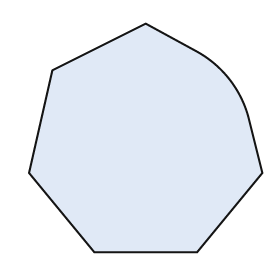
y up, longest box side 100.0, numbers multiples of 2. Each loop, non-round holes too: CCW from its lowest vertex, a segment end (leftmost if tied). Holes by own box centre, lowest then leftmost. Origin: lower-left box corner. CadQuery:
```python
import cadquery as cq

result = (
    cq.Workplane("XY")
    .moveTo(28.0, 0.0)
    .lineTo(72.0, 0.0)
    .lineTo(100.0, 34.0)
    .lineTo(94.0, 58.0)
    .threePointArc((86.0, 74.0), (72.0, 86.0))
    .lineTo(50.0, 98.0)
    .lineTo(10.0, 78.0)
    .lineTo(0.0, 34.0)
    .close()
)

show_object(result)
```